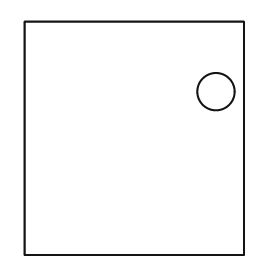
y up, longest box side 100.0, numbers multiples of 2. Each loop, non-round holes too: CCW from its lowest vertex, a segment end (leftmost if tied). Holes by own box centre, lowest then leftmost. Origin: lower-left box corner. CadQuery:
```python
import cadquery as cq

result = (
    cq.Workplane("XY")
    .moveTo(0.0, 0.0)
    .lineTo(94.0, 0.0)
    .lineTo(94.0, 100.0)
    .lineTo(0.0, 100.0)
    .close()
    .moveTo(82.0, 70.0)
    .circle(8.0)
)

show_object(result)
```